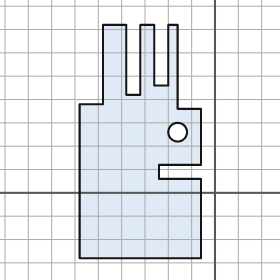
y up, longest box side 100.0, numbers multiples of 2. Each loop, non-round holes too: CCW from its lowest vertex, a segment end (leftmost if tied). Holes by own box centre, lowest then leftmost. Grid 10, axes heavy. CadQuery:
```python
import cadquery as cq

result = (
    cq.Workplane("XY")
    .moveTo(-58.0, -28.0)
    .lineTo(-6.0, -28.0)
    .lineTo(-6.0, 6.0)
    .lineTo(-24.0, 6.0)
    .lineTo(-24.0, 12.0)
    .lineTo(-6.0, 12.0)
    .lineTo(-6.0, 36.0)
    .lineTo(-16.0, 36.0)
    .lineTo(-16.0, 72.0)
    .lineTo(-20.0, 72.0)
    .lineTo(-20.0, 46.0)
    .lineTo(-26.0, 46.0)
    .lineTo(-26.0, 72.0)
    .lineTo(-32.0, 72.0)
    .lineTo(-32.0, 42.0)
    .lineTo(-38.0, 42.0)
    .lineTo(-38.0, 72.0)
    .lineTo(-48.0, 72.0)
    .lineTo(-48.0, 38.0)
    .lineTo(-58.0, 38.0)
    .close()
    .moveTo(-16.0, 26.0)
    .circle(4.0)
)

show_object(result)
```